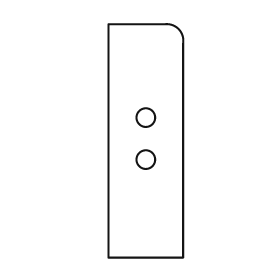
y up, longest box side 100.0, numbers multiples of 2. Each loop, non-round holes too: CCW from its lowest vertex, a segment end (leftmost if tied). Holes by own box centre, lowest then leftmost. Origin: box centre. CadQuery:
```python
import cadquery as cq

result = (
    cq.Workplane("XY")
    .moveTo(-16.0, -50.0)
    .lineTo(16.0, -50.0)
    .lineTo(16.0, 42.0)
    .threePointArc((14.0, 48.0), (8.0, 50.0))
    .lineTo(-16.0, 50.0)
    .close()
    .moveTo(0.0, -8.0)
    .circle(4.0)
    .moveTo(0.0, 10.0)
    .circle(4.0)
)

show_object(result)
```